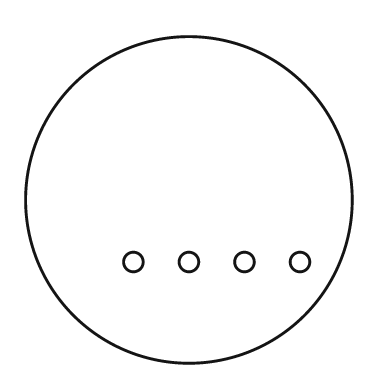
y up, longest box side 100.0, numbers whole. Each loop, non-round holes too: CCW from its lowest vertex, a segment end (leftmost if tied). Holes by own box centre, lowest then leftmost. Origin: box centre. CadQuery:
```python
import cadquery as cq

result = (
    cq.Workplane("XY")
    .moveTo(0.0, 0.0)
    .circle(50.0)
    .moveTo(-17.0, -19.0)
    .circle(3.0)
    .moveTo(0.0, -19.0)
    .circle(3.0)
    .moveTo(17.0, -19.0)
    .circle(3.0)
    .moveTo(34.0, -19.0)
    .circle(3.0)
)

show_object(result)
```